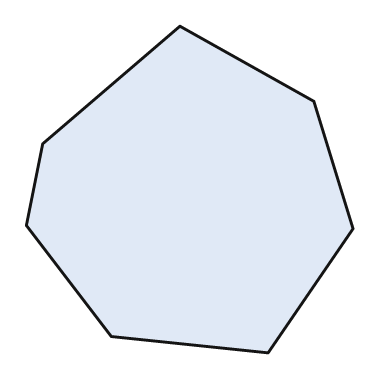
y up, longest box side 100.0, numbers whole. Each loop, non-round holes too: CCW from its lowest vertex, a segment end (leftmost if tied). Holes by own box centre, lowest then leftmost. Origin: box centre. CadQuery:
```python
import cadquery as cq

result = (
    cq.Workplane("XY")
    .moveTo(24.0, -50.0)
    .lineTo(50.0, -12.0)
    .lineTo(38.0, 27.0)
    .lineTo(-3.0, 50.0)
    .lineTo(-45.0, 14.0)
    .lineTo(-50.0, -11.0)
    .lineTo(-24.0, -45.0)
    .close()
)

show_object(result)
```